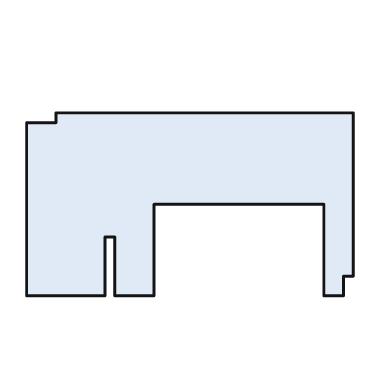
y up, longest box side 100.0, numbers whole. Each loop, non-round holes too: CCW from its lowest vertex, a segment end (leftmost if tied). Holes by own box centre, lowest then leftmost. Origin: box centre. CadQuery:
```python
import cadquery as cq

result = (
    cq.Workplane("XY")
    .moveTo(-50.0, -28.0)
    .lineTo(-26.0, -28.0)
    .lineTo(-26.0, -10.0)
    .lineTo(-23.0, -10.0)
    .lineTo(-23.0, -28.0)
    .lineTo(-11.0, -28.0)
    .lineTo(-11.0, 0.0)
    .lineTo(41.0, 0.0)
    .lineTo(41.0, -28.0)
    .lineTo(47.0, -28.0)
    .lineTo(47.0, -22.0)
    .lineTo(50.0, -22.0)
    .lineTo(50.0, 28.0)
    .lineTo(-41.0, 28.0)
    .lineTo(-41.0, 25.0)
    .lineTo(-50.0, 25.0)
    .close()
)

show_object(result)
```